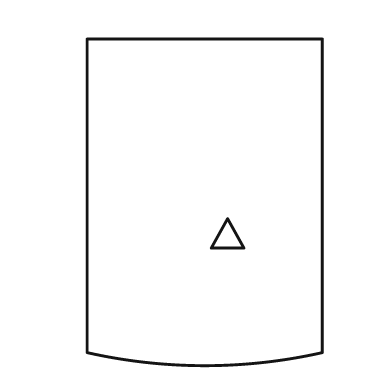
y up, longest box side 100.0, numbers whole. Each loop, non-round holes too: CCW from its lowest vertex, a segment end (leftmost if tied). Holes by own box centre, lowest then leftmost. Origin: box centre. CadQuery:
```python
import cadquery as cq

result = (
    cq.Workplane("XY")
    .moveTo(-36.0, -46.0)
    .threePointArc((0.0, -50.0), (36.0, -46.0))
    .lineTo(36.0, 50.0)
    .lineTo(-36.0, 50.0)
    .close()
    .moveTo(2.0, -14.0)
    .lineTo(12.0, -14.0)
    .lineTo(7.0, -5.0)
    .close()
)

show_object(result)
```